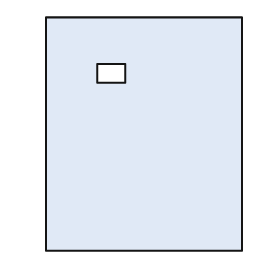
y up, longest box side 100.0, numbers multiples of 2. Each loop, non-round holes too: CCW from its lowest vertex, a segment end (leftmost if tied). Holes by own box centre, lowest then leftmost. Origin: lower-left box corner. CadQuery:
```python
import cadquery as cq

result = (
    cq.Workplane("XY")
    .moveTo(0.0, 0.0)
    .lineTo(84.0, 0.0)
    .lineTo(84.0, 100.0)
    .lineTo(0.0, 100.0)
    .close()
    .moveTo(22.0, 72.0)
    .lineTo(34.0, 72.0)
    .lineTo(34.0, 80.0)
    .lineTo(22.0, 80.0)
    .close()
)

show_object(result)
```